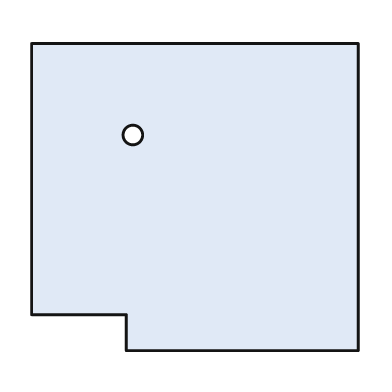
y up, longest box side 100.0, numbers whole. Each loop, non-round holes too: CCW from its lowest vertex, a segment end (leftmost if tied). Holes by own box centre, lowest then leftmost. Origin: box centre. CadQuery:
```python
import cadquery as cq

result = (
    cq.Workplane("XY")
    .moveTo(-21.0, -47.0)
    .lineTo(50.0, -47.0)
    .lineTo(50.0, 47.0)
    .lineTo(-50.0, 47.0)
    .lineTo(-50.0, -36.0)
    .lineTo(-21.0, -36.0)
    .close()
    .moveTo(-19.0, 19.0)
    .circle(3.0)
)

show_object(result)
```